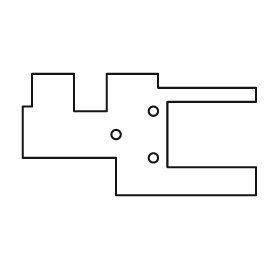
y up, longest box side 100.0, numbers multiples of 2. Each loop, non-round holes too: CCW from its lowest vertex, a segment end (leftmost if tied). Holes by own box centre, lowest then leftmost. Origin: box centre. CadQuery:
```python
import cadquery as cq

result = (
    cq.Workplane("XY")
    .moveTo(-10.0, -26.0)
    .lineTo(50.0, -26.0)
    .lineTo(50.0, -14.0)
    .lineTo(12.0, -14.0)
    .lineTo(12.0, 14.0)
    .lineTo(50.0, 14.0)
    .lineTo(50.0, 20.0)
    .lineTo(8.0, 20.0)
    .lineTo(8.0, 26.0)
    .lineTo(-14.0, 26.0)
    .lineTo(-14.0, 10.0)
    .lineTo(-28.0, 10.0)
    .lineTo(-28.0, 26.0)
    .lineTo(-46.0, 26.0)
    .lineTo(-46.0, 12.0)
    .lineTo(-50.0, 12.0)
    .lineTo(-50.0, -10.0)
    .lineTo(-10.0, -10.0)
    .close()
    .moveTo(6.0, -10.0)
    .circle(2.0)
    .moveTo(-10.0, 0.0)
    .circle(2.0)
    .moveTo(6.0, 10.0)
    .circle(2.0)
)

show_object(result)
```